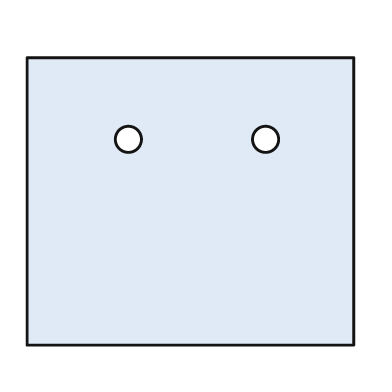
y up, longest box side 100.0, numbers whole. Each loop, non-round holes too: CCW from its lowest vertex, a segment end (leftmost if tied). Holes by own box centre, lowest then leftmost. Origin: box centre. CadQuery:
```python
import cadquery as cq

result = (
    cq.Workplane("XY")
    .moveTo(-50.0, -44.0)
    .lineTo(50.0, -44.0)
    .lineTo(50.0, 44.0)
    .lineTo(-50.0, 44.0)
    .close()
    .moveTo(-19.0, 19.0)
    .circle(4.0)
    .moveTo(23.0, 19.0)
    .circle(4.0)
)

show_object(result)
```